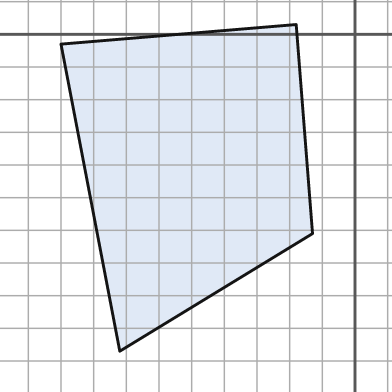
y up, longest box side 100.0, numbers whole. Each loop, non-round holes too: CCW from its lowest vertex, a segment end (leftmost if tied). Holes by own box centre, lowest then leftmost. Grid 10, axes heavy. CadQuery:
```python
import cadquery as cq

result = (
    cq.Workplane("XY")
    .moveTo(-72.0, -97.0)
    .lineTo(-13.0, -61.0)
    .lineTo(-18.0, 3.0)
    .lineTo(-90.0, -3.0)
    .close()
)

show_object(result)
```